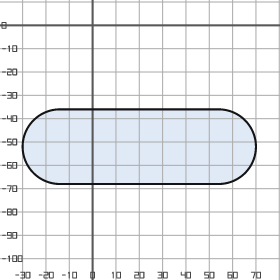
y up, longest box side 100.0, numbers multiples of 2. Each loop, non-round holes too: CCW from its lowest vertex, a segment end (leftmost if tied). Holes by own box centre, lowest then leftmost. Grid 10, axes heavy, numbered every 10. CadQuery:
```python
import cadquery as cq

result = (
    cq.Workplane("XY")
    .moveTo(-14.0, -68.0)
    .lineTo(54.0, -68.0)
    .threePointArc((70.0, -52.0), (54.0, -36.0))
    .lineTo(-14.0, -36.0)
    .threePointArc((-30.0, -52.0), (-14.0, -68.0))
    .close()
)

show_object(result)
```